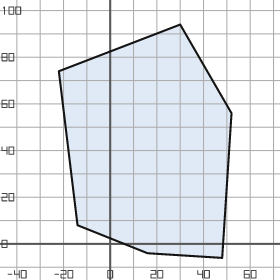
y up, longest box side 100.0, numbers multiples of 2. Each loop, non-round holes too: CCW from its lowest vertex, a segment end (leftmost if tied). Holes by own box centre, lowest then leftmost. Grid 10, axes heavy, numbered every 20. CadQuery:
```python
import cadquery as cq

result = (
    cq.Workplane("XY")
    .moveTo(48.0, -6.0)
    .lineTo(52.0, 56.0)
    .lineTo(30.0, 94.0)
    .lineTo(-22.0, 74.0)
    .lineTo(-14.0, 8.0)
    .lineTo(16.0, -4.0)
    .close()
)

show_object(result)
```